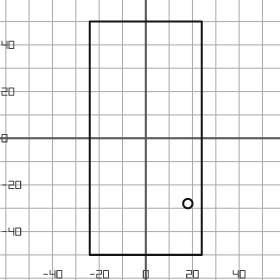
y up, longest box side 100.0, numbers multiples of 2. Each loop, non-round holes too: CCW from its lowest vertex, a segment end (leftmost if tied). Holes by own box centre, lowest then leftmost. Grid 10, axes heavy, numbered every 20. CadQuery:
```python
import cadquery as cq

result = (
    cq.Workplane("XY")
    .moveTo(-24.0, -50.0)
    .lineTo(24.0, -50.0)
    .lineTo(24.0, 50.0)
    .lineTo(-24.0, 50.0)
    .close()
    .moveTo(18.0, -28.0)
    .circle(2.0)
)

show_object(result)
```